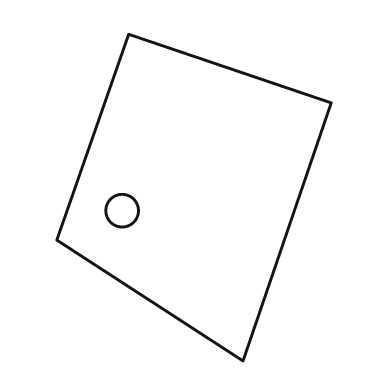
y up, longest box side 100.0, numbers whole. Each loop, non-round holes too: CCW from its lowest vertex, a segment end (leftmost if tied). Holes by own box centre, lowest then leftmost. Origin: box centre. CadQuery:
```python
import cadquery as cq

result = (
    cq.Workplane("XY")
    .moveTo(15.0, -50.0)
    .lineTo(42.0, 29.0)
    .lineTo(-20.0, 50.0)
    .lineTo(-42.0, -13.0)
    .close()
    .moveTo(-22.0, -4.0)
    .circle(5.0)
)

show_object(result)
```